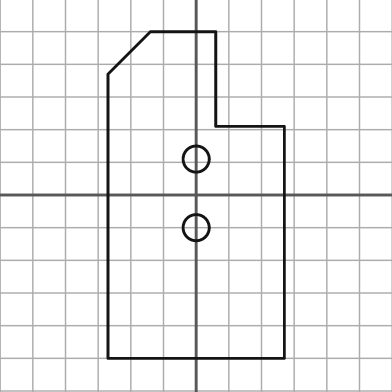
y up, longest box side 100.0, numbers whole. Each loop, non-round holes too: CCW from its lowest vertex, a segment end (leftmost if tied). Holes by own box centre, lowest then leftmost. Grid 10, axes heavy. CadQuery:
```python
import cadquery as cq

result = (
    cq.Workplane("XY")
    .moveTo(-27.0, -50.0)
    .lineTo(27.0, -50.0)
    .lineTo(27.0, 21.0)
    .lineTo(6.0, 21.0)
    .lineTo(6.0, 50.0)
    .lineTo(-14.0, 50.0)
    .lineTo(-27.0, 37.0)
    .close()
    .moveTo(0.0, -10.0)
    .circle(4.0)
    .moveTo(0.0, 11.0)
    .circle(4.0)
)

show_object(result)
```